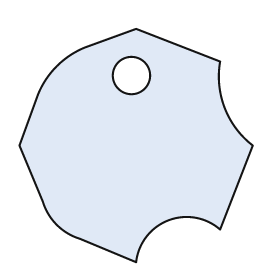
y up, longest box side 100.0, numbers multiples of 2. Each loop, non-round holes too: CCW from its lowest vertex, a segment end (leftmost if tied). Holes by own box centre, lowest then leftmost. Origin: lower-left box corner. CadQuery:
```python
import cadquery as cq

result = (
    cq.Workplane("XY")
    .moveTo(50.0, 0.0)
    .threePointArc((64.0, 18.0), (86.0, 14.0))
    .lineTo(100.0, 50.0)
    .threePointArc((88.0, 66.0), (86.0, 86.0))
    .lineTo(50.0, 100.0)
    .lineTo(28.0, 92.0)
    .threePointArc((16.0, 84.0), (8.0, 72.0))
    .lineTo(0.0, 50.0)
    .lineTo(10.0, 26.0)
    .threePointArc((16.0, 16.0), (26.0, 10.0))
    .close()
    .moveTo(48.0, 80.0)
    .circle(8.0)
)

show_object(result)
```